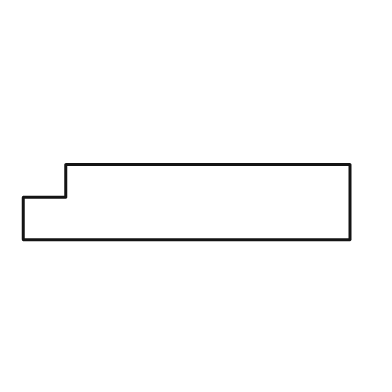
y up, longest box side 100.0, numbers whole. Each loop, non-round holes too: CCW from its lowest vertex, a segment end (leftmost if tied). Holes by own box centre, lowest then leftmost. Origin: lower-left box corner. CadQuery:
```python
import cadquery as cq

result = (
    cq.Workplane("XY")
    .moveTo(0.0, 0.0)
    .lineTo(100.0, 0.0)
    .lineTo(100.0, 23.0)
    .lineTo(13.0, 23.0)
    .lineTo(13.0, 13.0)
    .lineTo(0.0, 13.0)
    .close()
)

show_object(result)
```